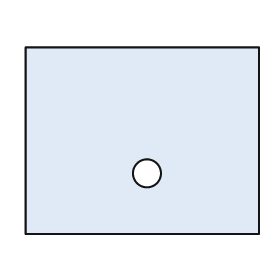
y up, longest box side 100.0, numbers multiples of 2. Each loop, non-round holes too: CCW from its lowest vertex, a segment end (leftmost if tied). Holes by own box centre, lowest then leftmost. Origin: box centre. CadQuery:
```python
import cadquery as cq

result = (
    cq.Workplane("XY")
    .moveTo(-50.0, -40.0)
    .lineTo(50.0, -40.0)
    .lineTo(50.0, 40.0)
    .lineTo(-50.0, 40.0)
    .close()
    .moveTo(2.0, -14.0)
    .circle(6.0)
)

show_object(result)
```